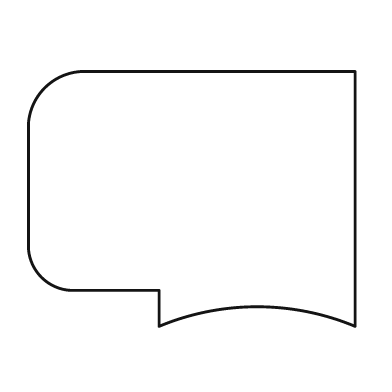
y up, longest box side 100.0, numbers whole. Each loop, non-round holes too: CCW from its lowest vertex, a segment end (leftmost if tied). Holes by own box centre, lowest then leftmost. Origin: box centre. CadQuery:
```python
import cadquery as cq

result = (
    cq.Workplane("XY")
    .moveTo(-10.0, -39.0)
    .threePointArc((20.0, -33.0), (50.0, -39.0))
    .lineTo(50.0, 39.0)
    .lineTo(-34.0, 39.0)
    .threePointArc((-45.0, 34.0), (-50.0, 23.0))
    .lineTo(-50.0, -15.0)
    .threePointArc((-46.0, -24.0), (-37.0, -28.0))
    .lineTo(-10.0, -28.0)
    .close()
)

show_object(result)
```